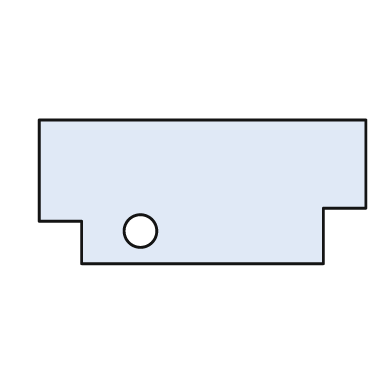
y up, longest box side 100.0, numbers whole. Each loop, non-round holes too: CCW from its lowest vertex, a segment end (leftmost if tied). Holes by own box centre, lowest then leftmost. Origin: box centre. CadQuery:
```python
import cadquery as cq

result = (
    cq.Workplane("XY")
    .moveTo(-37.0, -22.0)
    .lineTo(37.0, -22.0)
    .lineTo(37.0, -5.0)
    .lineTo(50.0, -5.0)
    .lineTo(50.0, 22.0)
    .lineTo(-50.0, 22.0)
    .lineTo(-50.0, -9.0)
    .lineTo(-37.0, -9.0)
    .close()
    .moveTo(-19.0, -12.0)
    .circle(5.0)
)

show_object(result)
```